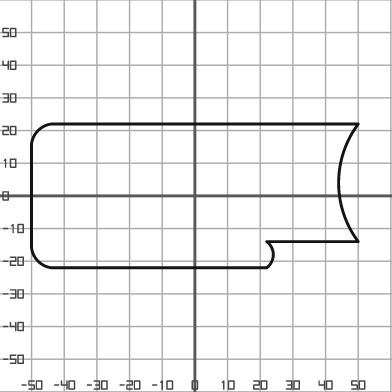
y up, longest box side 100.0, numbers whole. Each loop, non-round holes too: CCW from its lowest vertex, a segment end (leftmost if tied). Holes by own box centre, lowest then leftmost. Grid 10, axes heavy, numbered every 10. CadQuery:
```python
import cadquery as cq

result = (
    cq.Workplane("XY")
    .moveTo(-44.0, -22.0)
    .lineTo(22.0, -22.0)
    .threePointArc((24.0, -18.0), (22.0, -14.0))
    .lineTo(50.0, -14.0)
    .threePointArc((44.0, 4.0), (50.0, 22.0))
    .lineTo(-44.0, 22.0)
    .threePointArc((-48.0, 20.0), (-50.0, 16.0))
    .lineTo(-50.0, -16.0)
    .threePointArc((-48.0, -20.0), (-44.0, -22.0))
    .close()
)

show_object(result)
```